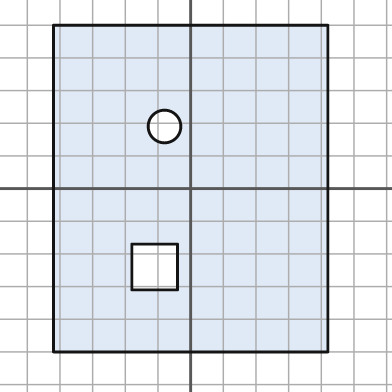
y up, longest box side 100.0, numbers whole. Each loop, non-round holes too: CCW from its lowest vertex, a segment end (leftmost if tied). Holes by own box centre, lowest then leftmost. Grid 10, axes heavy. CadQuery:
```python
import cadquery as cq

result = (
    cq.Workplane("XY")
    .moveTo(-42.0, -50.0)
    .lineTo(42.0, -50.0)
    .lineTo(42.0, 50.0)
    .lineTo(-42.0, 50.0)
    .close()
    .moveTo(-18.0, -31.0)
    .lineTo(-4.0, -31.0)
    .lineTo(-4.0, -17.0)
    .lineTo(-18.0, -17.0)
    .close()
    .moveTo(-8.0, 19.0)
    .circle(5.0)
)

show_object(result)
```